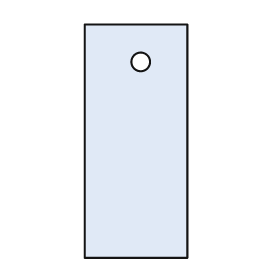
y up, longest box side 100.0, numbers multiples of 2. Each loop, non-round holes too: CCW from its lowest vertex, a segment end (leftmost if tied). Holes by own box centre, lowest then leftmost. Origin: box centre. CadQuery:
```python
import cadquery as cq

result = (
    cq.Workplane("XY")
    .moveTo(-22.0, -50.0)
    .lineTo(22.0, -50.0)
    .lineTo(22.0, 50.0)
    .lineTo(-22.0, 50.0)
    .close()
    .moveTo(2.0, 34.0)
    .circle(4.0)
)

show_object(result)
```